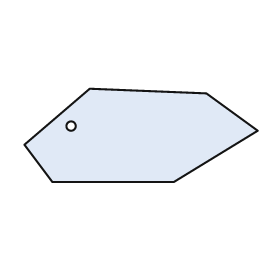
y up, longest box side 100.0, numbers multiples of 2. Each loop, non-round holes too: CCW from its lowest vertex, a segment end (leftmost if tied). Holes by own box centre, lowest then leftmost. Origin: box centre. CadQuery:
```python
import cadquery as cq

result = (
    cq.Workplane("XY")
    .moveTo(-38.0, -20.0)
    .lineTo(14.0, -20.0)
    .lineTo(50.0, 2.0)
    .lineTo(28.0, 18.0)
    .lineTo(-22.0, 20.0)
    .lineTo(-50.0, -4.0)
    .close()
    .moveTo(-30.0, 4.0)
    .circle(2.0)
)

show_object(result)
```